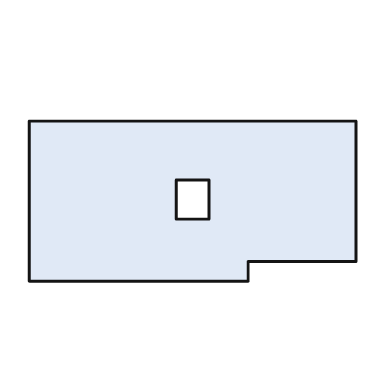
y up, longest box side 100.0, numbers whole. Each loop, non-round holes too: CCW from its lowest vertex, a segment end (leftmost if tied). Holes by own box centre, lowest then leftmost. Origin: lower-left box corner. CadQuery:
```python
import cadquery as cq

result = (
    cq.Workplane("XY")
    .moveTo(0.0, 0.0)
    .lineTo(67.0, 0.0)
    .lineTo(67.0, 6.0)
    .lineTo(100.0, 6.0)
    .lineTo(100.0, 49.0)
    .lineTo(0.0, 49.0)
    .close()
    .moveTo(45.0, 19.0)
    .lineTo(55.0, 19.0)
    .lineTo(55.0, 31.0)
    .lineTo(45.0, 31.0)
    .close()
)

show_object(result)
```